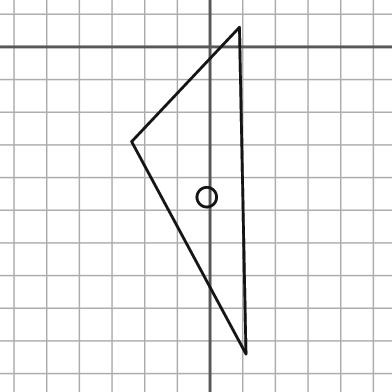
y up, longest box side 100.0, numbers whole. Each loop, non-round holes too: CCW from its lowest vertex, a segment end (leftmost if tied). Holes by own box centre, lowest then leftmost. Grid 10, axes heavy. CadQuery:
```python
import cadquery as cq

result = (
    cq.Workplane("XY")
    .moveTo(11.0, -94.0)
    .lineTo(9.0, 6.0)
    .lineTo(-24.0, -29.0)
    .close()
    .moveTo(-1.0, -46.0)
    .circle(3.0)
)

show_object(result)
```